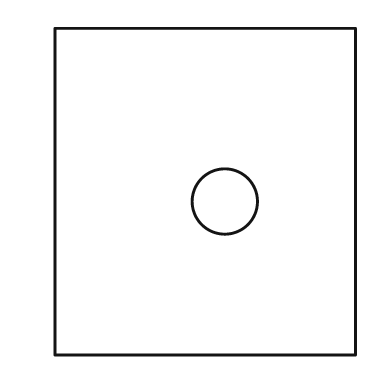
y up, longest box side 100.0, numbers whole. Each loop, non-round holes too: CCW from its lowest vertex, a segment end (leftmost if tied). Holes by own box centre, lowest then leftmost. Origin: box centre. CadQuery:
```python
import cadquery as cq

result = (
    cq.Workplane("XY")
    .moveTo(-46.0, -50.0)
    .lineTo(46.0, -50.0)
    .lineTo(46.0, 50.0)
    .lineTo(-46.0, 50.0)
    .close()
    .moveTo(6.0, -3.0)
    .circle(10.0)
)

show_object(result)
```